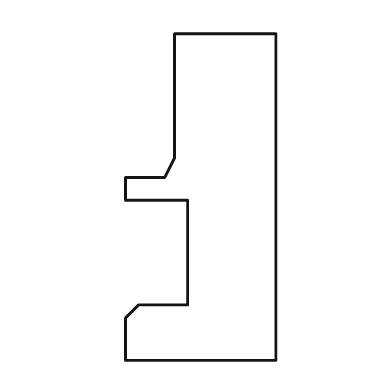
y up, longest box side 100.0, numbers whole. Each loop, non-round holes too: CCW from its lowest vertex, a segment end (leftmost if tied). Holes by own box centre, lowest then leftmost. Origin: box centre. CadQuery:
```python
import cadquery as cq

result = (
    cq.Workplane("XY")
    .moveTo(-23.0, -50.0)
    .lineTo(23.0, -50.0)
    .lineTo(23.0, 50.0)
    .lineTo(-8.0, 50.0)
    .lineTo(-8.0, 12.0)
    .lineTo(-11.0, 6.0)
    .lineTo(-23.0, 6.0)
    .lineTo(-23.0, -1.0)
    .lineTo(-4.0, -1.0)
    .lineTo(-4.0, -33.0)
    .lineTo(-19.0, -33.0)
    .lineTo(-23.0, -37.0)
    .close()
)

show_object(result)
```